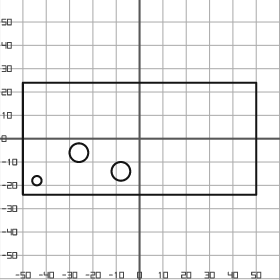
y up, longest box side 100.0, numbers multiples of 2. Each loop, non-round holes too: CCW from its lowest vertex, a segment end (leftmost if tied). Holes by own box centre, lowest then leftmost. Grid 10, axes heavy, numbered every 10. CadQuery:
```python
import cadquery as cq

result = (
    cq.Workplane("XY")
    .moveTo(-50.0, -24.0)
    .lineTo(50.0, -24.0)
    .lineTo(50.0, 24.0)
    .lineTo(-50.0, 24.0)
    .close()
    .moveTo(-44.0, -18.0)
    .circle(2.0)
    .moveTo(-8.0, -14.0)
    .circle(4.0)
    .moveTo(-26.0, -6.0)
    .circle(4.0)
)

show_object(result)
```